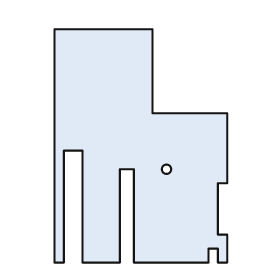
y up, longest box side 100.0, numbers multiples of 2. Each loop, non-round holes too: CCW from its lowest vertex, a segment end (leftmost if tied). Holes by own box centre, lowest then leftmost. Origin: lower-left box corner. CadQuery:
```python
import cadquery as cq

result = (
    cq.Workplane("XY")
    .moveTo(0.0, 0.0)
    .lineTo(4.0, 0.0)
    .lineTo(4.0, 48.0)
    .lineTo(12.0, 48.0)
    .lineTo(12.0, 0.0)
    .lineTo(28.0, 0.0)
    .lineTo(28.0, 40.0)
    .lineTo(34.0, 40.0)
    .lineTo(34.0, 0.0)
    .lineTo(66.0, 0.0)
    .lineTo(66.0, 6.0)
    .lineTo(70.0, 6.0)
    .lineTo(70.0, 0.0)
    .lineTo(74.0, 0.0)
    .lineTo(74.0, 12.0)
    .lineTo(70.0, 12.0)
    .lineTo(70.0, 34.0)
    .lineTo(74.0, 34.0)
    .lineTo(74.0, 64.0)
    .lineTo(42.0, 64.0)
    .lineTo(42.0, 100.0)
    .lineTo(0.0, 100.0)
    .close()
    .moveTo(48.0, 40.0)
    .circle(2.0)
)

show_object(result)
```